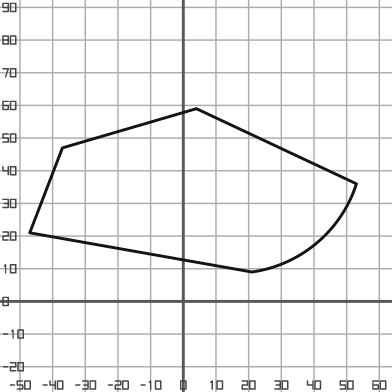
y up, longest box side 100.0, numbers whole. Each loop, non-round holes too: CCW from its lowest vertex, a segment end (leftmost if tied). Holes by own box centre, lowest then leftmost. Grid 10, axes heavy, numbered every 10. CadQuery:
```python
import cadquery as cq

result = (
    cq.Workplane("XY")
    .moveTo(21.0, 9.0)
    .threePointArc((41.0, 18.0), (53.0, 36.0))
    .lineTo(4.0, 59.0)
    .lineTo(-37.0, 47.0)
    .lineTo(-47.0, 21.0)
    .close()
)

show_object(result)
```